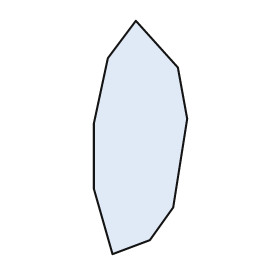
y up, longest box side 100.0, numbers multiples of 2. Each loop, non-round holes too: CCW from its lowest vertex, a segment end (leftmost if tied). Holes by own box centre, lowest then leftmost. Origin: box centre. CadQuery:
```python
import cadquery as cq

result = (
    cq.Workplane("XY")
    .moveTo(-12.0, -50.0)
    .lineTo(4.0, -44.0)
    .lineTo(14.0, -30.0)
    .lineTo(20.0, 8.0)
    .lineTo(16.0, 30.0)
    .lineTo(-2.0, 50.0)
    .lineTo(-14.0, 34.0)
    .lineTo(-20.0, 6.0)
    .lineTo(-20.0, -22.0)
    .close()
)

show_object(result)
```